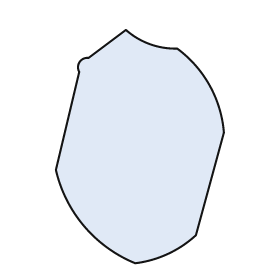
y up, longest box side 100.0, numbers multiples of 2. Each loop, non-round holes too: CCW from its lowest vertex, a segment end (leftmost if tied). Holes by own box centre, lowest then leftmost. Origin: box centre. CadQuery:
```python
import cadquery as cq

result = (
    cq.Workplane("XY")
    .moveTo(-2.0, -50.0)
    .threePointArc((12.0, -46.0), (24.0, -38.0))
    .lineTo(36.0, 6.0)
    .threePointArc((30.0, 26.0), (16.0, 42.0))
    .threePointArc((4.0, 44.0), (-6.0, 50.0))
    .lineTo(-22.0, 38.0)
    .threePointArc((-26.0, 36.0), (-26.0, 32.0))
    .lineTo(-36.0, -10.0)
    .threePointArc((-24.0, -34.0), (-2.0, -50.0))
    .close()
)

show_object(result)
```